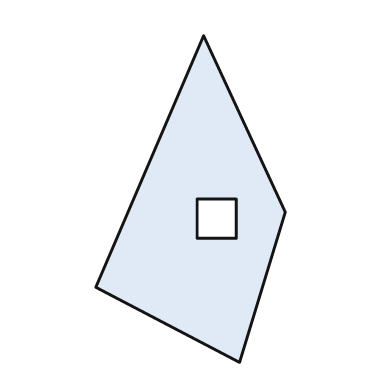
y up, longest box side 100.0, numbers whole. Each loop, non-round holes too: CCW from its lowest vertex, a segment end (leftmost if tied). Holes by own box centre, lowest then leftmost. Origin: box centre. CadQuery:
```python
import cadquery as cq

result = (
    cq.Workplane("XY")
    .moveTo(15.0, -50.0)
    .lineTo(29.0, -4.0)
    .lineTo(4.0, 50.0)
    .lineTo(-29.0, -27.0)
    .close()
    .moveTo(2.0, -12.0)
    .lineTo(14.0, -12.0)
    .lineTo(14.0, 0.0)
    .lineTo(2.0, 0.0)
    .close()
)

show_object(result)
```